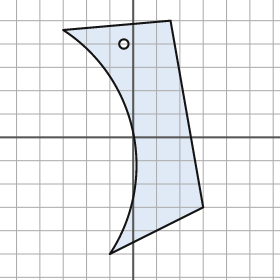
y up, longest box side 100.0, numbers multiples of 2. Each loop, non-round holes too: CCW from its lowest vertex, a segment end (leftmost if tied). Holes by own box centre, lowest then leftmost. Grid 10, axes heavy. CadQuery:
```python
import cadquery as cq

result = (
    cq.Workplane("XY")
    .moveTo(-10.0, -50.0)
    .lineTo(30.0, -30.0)
    .lineTo(16.0, 50.0)
    .lineTo(-30.0, 46.0)
    .threePointArc((0.0, 2.0), (-10.0, -50.0))
    .close()
    .moveTo(-4.0, 40.0)
    .circle(2.0)
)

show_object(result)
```